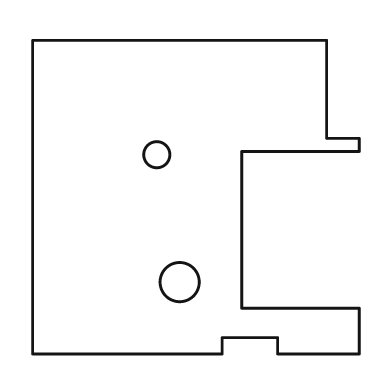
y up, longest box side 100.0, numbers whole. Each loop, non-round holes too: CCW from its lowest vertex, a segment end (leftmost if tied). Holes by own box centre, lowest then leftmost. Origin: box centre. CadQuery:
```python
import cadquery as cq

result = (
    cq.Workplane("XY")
    .moveTo(-50.0, -48.0)
    .lineTo(8.0, -48.0)
    .lineTo(8.0, -43.0)
    .lineTo(25.0, -43.0)
    .lineTo(25.0, -48.0)
    .lineTo(50.0, -48.0)
    .lineTo(50.0, -34.0)
    .lineTo(14.0, -34.0)
    .lineTo(14.0, 14.0)
    .lineTo(50.0, 14.0)
    .lineTo(50.0, 18.0)
    .lineTo(40.0, 18.0)
    .lineTo(40.0, 48.0)
    .lineTo(-50.0, 48.0)
    .close()
    .moveTo(-5.0, -26.0)
    .circle(6.0)
    .moveTo(-12.0, 13.0)
    .circle(4.0)
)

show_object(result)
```